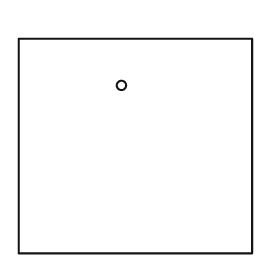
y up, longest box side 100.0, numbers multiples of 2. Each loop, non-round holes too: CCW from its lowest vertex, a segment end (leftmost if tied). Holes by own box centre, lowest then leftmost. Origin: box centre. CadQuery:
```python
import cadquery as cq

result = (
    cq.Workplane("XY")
    .moveTo(-50.0, -46.0)
    .lineTo(50.0, -46.0)
    .lineTo(50.0, 46.0)
    .lineTo(-50.0, 46.0)
    .close()
    .moveTo(-6.0, 26.0)
    .circle(2.0)
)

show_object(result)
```